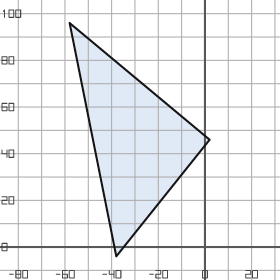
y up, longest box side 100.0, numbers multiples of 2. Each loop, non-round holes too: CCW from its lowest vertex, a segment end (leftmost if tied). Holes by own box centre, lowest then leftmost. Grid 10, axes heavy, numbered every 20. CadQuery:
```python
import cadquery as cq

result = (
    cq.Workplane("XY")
    .moveTo(-38.0, -4.0)
    .lineTo(2.0, 46.0)
    .lineTo(-58.0, 96.0)
    .close()
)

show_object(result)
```